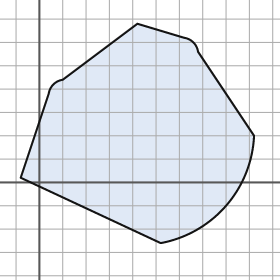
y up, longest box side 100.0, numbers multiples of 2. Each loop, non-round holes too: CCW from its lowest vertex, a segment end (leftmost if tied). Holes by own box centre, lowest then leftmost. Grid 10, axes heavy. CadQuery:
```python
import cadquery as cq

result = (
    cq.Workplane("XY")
    .moveTo(52.0, -26.0)
    .threePointArc((80.0, -10.0), (92.0, 20.0))
    .lineTo(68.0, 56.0)
    .threePointArc((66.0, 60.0), (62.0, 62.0))
    .lineTo(42.0, 68.0)
    .lineTo(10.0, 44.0)
    .threePointArc((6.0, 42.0), (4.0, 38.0))
    .lineTo(-8.0, 2.0)
    .close()
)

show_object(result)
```